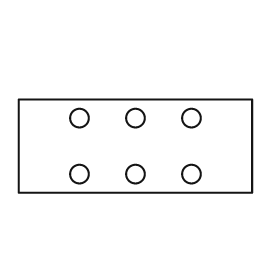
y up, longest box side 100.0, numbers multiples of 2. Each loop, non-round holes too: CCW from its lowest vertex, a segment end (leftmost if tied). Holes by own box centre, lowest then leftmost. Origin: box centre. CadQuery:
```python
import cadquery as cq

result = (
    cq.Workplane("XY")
    .moveTo(-50.0, -20.0)
    .lineTo(50.0, -20.0)
    .lineTo(50.0, 20.0)
    .lineTo(-50.0, 20.0)
    .close()
    .moveTo(-24.0, -12.0)
    .circle(4.0)
    .moveTo(0.0, -12.0)
    .circle(4.0)
    .moveTo(24.0, -12.0)
    .circle(4.0)
    .moveTo(-24.0, 12.0)
    .circle(4.0)
    .moveTo(0.0, 12.0)
    .circle(4.0)
    .moveTo(24.0, 12.0)
    .circle(4.0)
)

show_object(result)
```